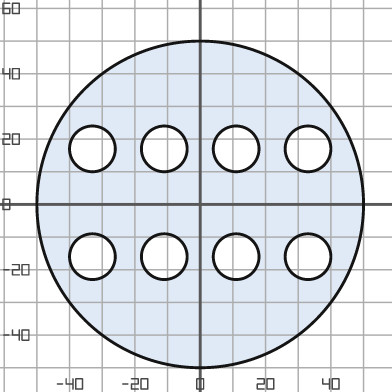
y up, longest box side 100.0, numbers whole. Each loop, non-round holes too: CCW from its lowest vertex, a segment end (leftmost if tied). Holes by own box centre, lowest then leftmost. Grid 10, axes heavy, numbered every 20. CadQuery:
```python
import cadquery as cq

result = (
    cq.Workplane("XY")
    .moveTo(0.0, 0.0)
    .circle(50.0)
    .moveTo(-33.0, -16.0)
    .circle(7.0)
    .moveTo(-11.0, -16.0)
    .circle(7.0)
    .moveTo(11.0, -16.0)
    .circle(7.0)
    .moveTo(33.0, -16.0)
    .circle(7.0)
    .moveTo(-33.0, 17.0)
    .circle(7.0)
    .moveTo(-11.0, 17.0)
    .circle(7.0)
    .moveTo(11.0, 17.0)
    .circle(7.0)
    .moveTo(33.0, 17.0)
    .circle(7.0)
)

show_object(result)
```